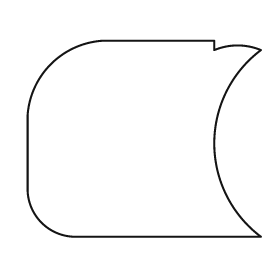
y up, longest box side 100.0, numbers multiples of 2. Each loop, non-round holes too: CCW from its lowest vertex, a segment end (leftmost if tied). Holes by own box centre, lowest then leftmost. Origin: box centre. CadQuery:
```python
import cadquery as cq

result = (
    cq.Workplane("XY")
    .moveTo(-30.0, -42.0)
    .lineTo(50.0, -42.0)
    .threePointArc((30.0, -2.0), (50.0, 38.0))
    .threePointArc((40.0, 40.0), (30.0, 38.0))
    .lineTo(30.0, 42.0)
    .lineTo(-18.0, 42.0)
    .threePointArc((-40.0, 32.0), (-50.0, 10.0))
    .lineTo(-50.0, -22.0)
    .threePointArc((-44.0, -36.0), (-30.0, -42.0))
    .close()
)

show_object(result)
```